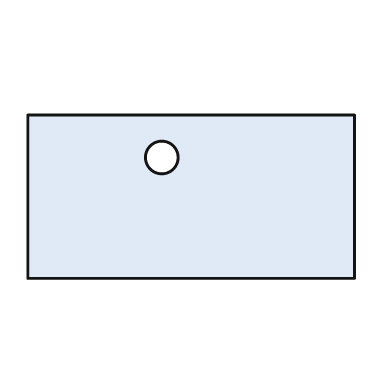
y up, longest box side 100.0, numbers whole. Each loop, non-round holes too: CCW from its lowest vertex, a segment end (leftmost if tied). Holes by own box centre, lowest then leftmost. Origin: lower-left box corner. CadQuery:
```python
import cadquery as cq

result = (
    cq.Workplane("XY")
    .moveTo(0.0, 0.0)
    .lineTo(100.0, 0.0)
    .lineTo(100.0, 50.0)
    .lineTo(0.0, 50.0)
    .close()
    .moveTo(41.0, 37.0)
    .circle(5.0)
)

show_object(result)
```